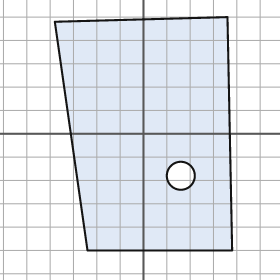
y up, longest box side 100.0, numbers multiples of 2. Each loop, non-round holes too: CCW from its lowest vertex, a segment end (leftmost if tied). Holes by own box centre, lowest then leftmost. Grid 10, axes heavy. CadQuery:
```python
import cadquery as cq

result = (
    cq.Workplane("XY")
    .moveTo(-24.0, -50.0)
    .lineTo(38.0, -50.0)
    .lineTo(36.0, 50.0)
    .lineTo(-38.0, 48.0)
    .close()
    .moveTo(16.0, -18.0)
    .circle(6.0)
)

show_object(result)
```